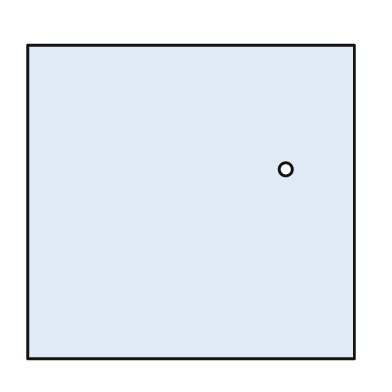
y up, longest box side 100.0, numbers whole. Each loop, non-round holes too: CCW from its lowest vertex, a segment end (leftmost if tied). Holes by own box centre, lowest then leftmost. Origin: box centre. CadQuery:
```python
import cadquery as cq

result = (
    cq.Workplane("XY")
    .moveTo(-50.0, -48.0)
    .lineTo(50.0, -48.0)
    .lineTo(50.0, 48.0)
    .lineTo(-50.0, 48.0)
    .close()
    .moveTo(29.0, 10.0)
    .circle(2.0)
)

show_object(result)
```